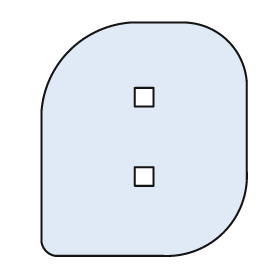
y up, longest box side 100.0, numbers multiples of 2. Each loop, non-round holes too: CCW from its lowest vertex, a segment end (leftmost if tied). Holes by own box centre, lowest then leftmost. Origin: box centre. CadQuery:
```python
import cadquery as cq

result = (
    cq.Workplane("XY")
    .moveTo(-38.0, -50.0)
    .lineTo(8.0, -50.0)
    .threePointArc((34.0, -40.0), (44.0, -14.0))
    .lineTo(44.0, 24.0)
    .threePointArc((36.0, 42.0), (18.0, 50.0))
    .lineTo(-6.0, 50.0)
    .threePointArc((-32.0, 38.0), (-44.0, 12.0))
    .lineTo(-44.0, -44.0)
    .threePointArc((-42.0, -48.0), (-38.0, -50.0))
    .close()
    .moveTo(-4.0, -20.0)
    .lineTo(4.0, -20.0)
    .lineTo(4.0, -12.0)
    .lineTo(-4.0, -12.0)
    .close()
    .moveTo(-4.0, 14.0)
    .lineTo(4.0, 14.0)
    .lineTo(4.0, 22.0)
    .lineTo(-4.0, 22.0)
    .close()
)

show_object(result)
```